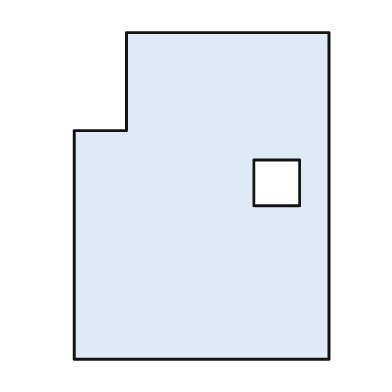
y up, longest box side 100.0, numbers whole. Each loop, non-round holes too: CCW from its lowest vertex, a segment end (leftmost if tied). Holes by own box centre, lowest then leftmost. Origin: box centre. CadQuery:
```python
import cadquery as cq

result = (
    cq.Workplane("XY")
    .moveTo(-39.0, -50.0)
    .lineTo(39.0, -50.0)
    .lineTo(39.0, 50.0)
    .lineTo(-23.0, 50.0)
    .lineTo(-23.0, 20.0)
    .lineTo(-39.0, 20.0)
    .close()
    .moveTo(16.0, -3.0)
    .lineTo(30.0, -3.0)
    .lineTo(30.0, 11.0)
    .lineTo(16.0, 11.0)
    .close()
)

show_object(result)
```